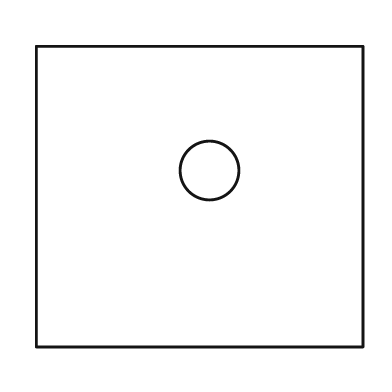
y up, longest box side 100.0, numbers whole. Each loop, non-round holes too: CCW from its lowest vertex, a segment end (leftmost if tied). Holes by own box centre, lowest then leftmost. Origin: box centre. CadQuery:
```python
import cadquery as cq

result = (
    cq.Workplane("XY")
    .moveTo(-50.0, -46.0)
    .lineTo(50.0, -46.0)
    .lineTo(50.0, 46.0)
    .lineTo(-50.0, 46.0)
    .close()
    .moveTo(3.0, 8.0)
    .circle(9.0)
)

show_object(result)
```